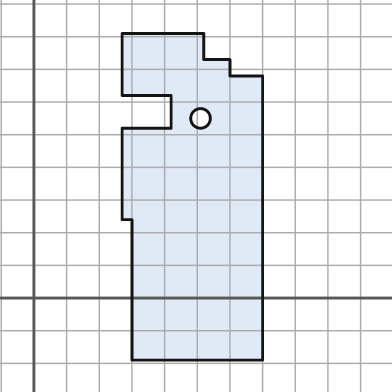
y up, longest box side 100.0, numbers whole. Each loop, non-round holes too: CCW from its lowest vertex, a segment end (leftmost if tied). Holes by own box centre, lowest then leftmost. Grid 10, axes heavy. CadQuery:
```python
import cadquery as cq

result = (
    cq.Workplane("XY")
    .moveTo(30.0, -19.0)
    .lineTo(70.0, -19.0)
    .lineTo(70.0, 68.0)
    .lineTo(60.0, 68.0)
    .lineTo(60.0, 73.0)
    .lineTo(52.0, 73.0)
    .lineTo(52.0, 81.0)
    .lineTo(27.0, 81.0)
    .lineTo(27.0, 62.0)
    .lineTo(42.0, 62.0)
    .lineTo(42.0, 52.0)
    .lineTo(27.0, 52.0)
    .lineTo(27.0, 24.0)
    .lineTo(30.0, 24.0)
    .close()
    .moveTo(51.0, 55.0)
    .circle(3.0)
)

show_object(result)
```